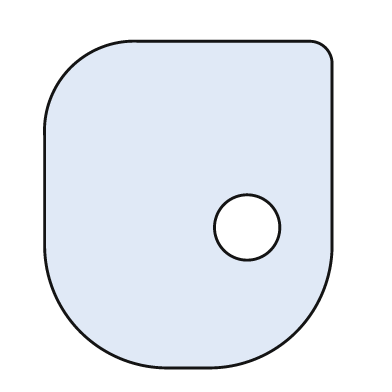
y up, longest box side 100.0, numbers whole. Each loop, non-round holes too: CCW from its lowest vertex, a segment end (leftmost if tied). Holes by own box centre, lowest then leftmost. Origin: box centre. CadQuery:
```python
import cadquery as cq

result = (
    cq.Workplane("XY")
    .moveTo(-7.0, -50.0)
    .lineTo(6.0, -50.0)
    .threePointArc((33.0, -39.0), (44.0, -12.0))
    .lineTo(44.0, 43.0)
    .threePointArc((42.0, 48.0), (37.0, 50.0))
    .lineTo(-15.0, 50.0)
    .threePointArc((-36.0, 42.0), (-44.0, 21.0))
    .lineTo(-44.0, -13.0)
    .threePointArc((-33.0, -39.0), (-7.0, -50.0))
    .close()
    .moveTo(18.0, -7.0)
    .circle(10.0)
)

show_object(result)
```